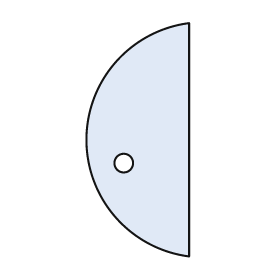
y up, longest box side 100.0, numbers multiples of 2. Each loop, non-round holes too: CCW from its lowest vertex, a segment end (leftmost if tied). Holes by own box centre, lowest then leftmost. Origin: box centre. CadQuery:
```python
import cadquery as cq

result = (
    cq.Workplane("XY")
    .moveTo(22.0, -50.0)
    .lineTo(22.0, 50.0)
    .threePointArc((-22.0, 0.0), (22.0, -50.0))
    .close()
    .moveTo(-6.0, -10.0)
    .circle(4.0)
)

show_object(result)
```